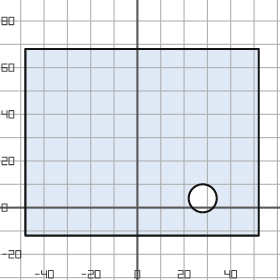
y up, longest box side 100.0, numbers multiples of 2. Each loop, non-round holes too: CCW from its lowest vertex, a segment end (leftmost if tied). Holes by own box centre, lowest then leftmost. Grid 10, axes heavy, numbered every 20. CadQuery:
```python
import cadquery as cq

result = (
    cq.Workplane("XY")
    .moveTo(-48.0, -12.0)
    .lineTo(52.0, -12.0)
    .lineTo(52.0, 68.0)
    .lineTo(-48.0, 68.0)
    .close()
    .moveTo(28.0, 4.0)
    .circle(6.0)
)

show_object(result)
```